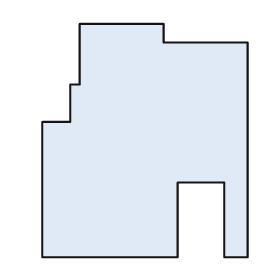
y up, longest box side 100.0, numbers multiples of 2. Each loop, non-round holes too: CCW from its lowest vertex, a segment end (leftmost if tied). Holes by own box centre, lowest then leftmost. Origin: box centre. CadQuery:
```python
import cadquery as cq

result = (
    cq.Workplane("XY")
    .moveTo(-44.0, -50.0)
    .lineTo(14.0, -50.0)
    .lineTo(14.0, -18.0)
    .lineTo(34.0, -18.0)
    .lineTo(34.0, -50.0)
    .lineTo(44.0, -50.0)
    .lineTo(44.0, 42.0)
    .lineTo(8.0, 42.0)
    .lineTo(8.0, 50.0)
    .lineTo(-28.0, 50.0)
    .lineTo(-28.0, 24.0)
    .lineTo(-32.0, 24.0)
    .lineTo(-32.0, 8.0)
    .lineTo(-44.0, 8.0)
    .close()
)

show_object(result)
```